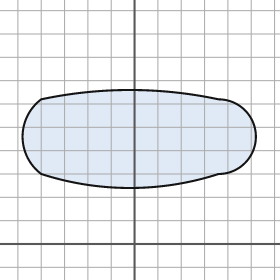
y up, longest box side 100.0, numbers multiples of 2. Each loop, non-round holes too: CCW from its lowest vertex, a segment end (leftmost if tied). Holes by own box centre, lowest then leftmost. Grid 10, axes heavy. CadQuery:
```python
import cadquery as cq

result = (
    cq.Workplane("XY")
    .moveTo(-40.0, 30.0)
    .threePointArc((-2.0, 24.0), (36.0, 30.0))
    .threePointArc((52.0, 46.0), (36.0, 62.0))
    .threePointArc((-2.0, 66.0), (-40.0, 62.0))
    .threePointArc((-48.0, 46.0), (-40.0, 30.0))
    .close()
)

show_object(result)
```